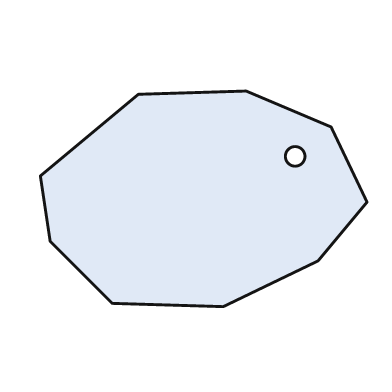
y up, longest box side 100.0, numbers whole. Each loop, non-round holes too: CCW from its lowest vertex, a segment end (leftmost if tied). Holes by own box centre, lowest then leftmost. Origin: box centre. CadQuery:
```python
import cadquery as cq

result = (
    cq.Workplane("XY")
    .moveTo(6.0, -33.0)
    .lineTo(35.0, -19.0)
    .lineTo(50.0, -1.0)
    .lineTo(39.0, 22.0)
    .lineTo(13.0, 33.0)
    .lineTo(-20.0, 32.0)
    .lineTo(-50.0, 7.0)
    .lineTo(-47.0, -13.0)
    .lineTo(-28.0, -32.0)
    .close()
    .moveTo(28.0, 13.0)
    .circle(3.0)
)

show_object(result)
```